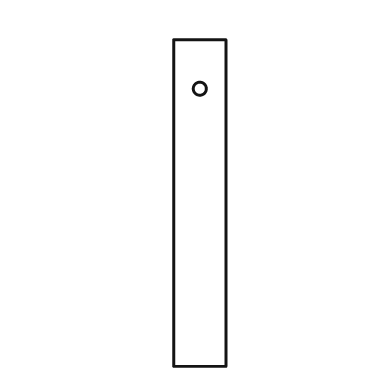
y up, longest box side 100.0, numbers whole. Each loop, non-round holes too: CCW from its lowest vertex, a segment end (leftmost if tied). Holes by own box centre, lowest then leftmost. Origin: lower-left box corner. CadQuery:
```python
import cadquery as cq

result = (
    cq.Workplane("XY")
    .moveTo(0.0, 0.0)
    .lineTo(16.0, 0.0)
    .lineTo(16.0, 100.0)
    .lineTo(0.0, 100.0)
    .close()
    .moveTo(8.0, 85.0)
    .circle(2.0)
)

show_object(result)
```